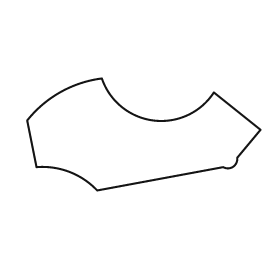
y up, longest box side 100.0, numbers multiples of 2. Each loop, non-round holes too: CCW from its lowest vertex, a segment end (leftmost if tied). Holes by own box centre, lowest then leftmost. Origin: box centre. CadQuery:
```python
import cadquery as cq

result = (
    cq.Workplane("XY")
    .moveTo(-20.0, -24.0)
    .lineTo(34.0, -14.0)
    .threePointArc((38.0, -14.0), (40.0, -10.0))
    .lineTo(50.0, 2.0)
    .lineTo(30.0, 18.0)
    .threePointArc((4.0, 6.0), (-18.0, 24.0))
    .threePointArc((-36.0, 18.0), (-50.0, 6.0))
    .lineTo(-46.0, -14.0)
    .threePointArc((-32.0, -16.0), (-20.0, -24.0))
    .close()
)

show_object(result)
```